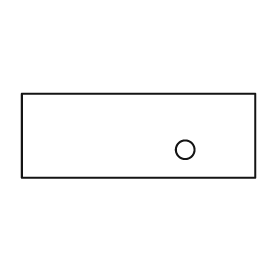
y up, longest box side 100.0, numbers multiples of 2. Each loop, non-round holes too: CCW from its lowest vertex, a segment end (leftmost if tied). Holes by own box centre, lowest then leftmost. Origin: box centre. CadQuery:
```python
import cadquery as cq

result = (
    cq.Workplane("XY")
    .moveTo(-50.0, -18.0)
    .lineTo(50.0, -18.0)
    .lineTo(50.0, 18.0)
    .lineTo(-50.0, 18.0)
    .close()
    .moveTo(20.0, -6.0)
    .circle(4.0)
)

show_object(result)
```